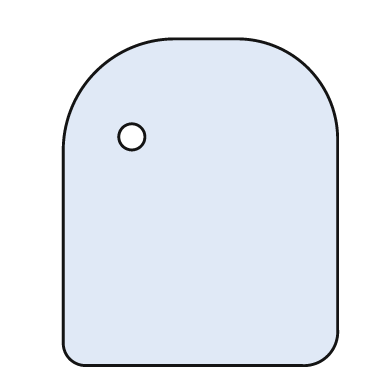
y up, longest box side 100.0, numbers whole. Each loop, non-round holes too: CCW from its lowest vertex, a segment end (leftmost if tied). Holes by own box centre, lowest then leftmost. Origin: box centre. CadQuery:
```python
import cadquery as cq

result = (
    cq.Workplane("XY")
    .moveTo(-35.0, -50.0)
    .lineTo(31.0, -50.0)
    .threePointArc((39.0, -47.0), (42.0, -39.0))
    .lineTo(42.0, 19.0)
    .threePointArc((33.0, 41.0), (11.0, 50.0))
    .lineTo(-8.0, 50.0)
    .threePointArc((-32.0, 40.0), (-42.0, 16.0))
    .lineTo(-42.0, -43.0)
    .threePointArc((-40.0, -48.0), (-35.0, -50.0))
    .close()
    .moveTo(-21.0, 20.0)
    .circle(4.0)
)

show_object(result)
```